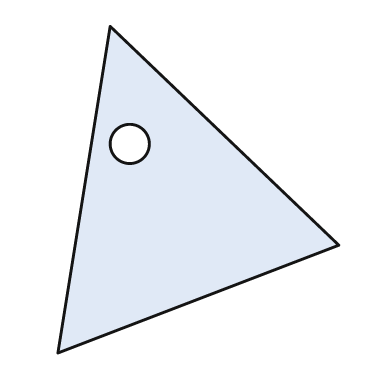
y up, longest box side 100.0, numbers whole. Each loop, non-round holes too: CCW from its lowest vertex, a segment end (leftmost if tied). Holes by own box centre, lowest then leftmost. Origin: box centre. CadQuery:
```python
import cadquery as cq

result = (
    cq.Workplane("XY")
    .moveTo(-43.0, -50.0)
    .lineTo(43.0, -17.0)
    .lineTo(-27.0, 50.0)
    .close()
    .moveTo(-21.0, 14.0)
    .circle(6.0)
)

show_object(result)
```